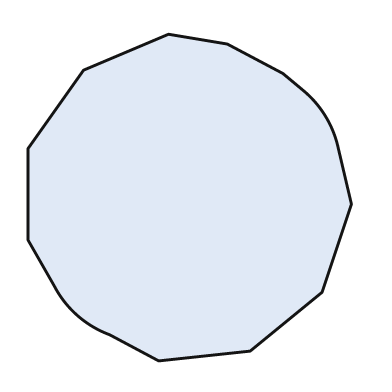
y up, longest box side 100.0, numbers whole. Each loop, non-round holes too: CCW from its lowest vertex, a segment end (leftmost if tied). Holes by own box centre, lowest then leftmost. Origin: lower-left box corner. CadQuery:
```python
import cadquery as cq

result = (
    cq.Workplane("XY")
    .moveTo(40.0, 0.0)
    .lineTo(68.0, 3.0)
    .lineTo(90.0, 21.0)
    .lineTo(99.0, 48.0)
    .lineTo(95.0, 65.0)
    .threePointArc((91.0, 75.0), (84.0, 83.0))
    .lineTo(78.0, 88.0)
    .lineTo(61.0, 97.0)
    .lineTo(43.0, 100.0)
    .lineTo(17.0, 89.0)
    .lineTo(0.0, 65.0)
    .lineTo(0.0, 37.0)
    .lineTo(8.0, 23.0)
    .threePointArc((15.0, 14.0), (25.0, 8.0))
    .close()
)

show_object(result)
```